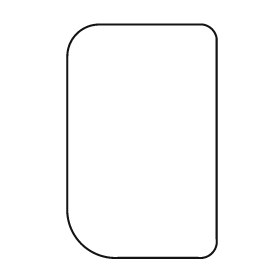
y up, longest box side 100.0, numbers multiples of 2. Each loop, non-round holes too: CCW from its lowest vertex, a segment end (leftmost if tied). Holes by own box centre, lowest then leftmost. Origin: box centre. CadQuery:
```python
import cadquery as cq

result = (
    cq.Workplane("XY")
    .moveTo(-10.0, -50.0)
    .lineTo(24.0, -50.0)
    .threePointArc((30.0, -48.0), (32.0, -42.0))
    .lineTo(32.0, 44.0)
    .threePointArc((30.0, 48.0), (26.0, 50.0))
    .lineTo(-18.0, 50.0)
    .threePointArc((-28.0, 46.0), (-32.0, 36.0))
    .lineTo(-32.0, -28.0)
    .threePointArc((-26.0, -44.0), (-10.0, -50.0))
    .close()
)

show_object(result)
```